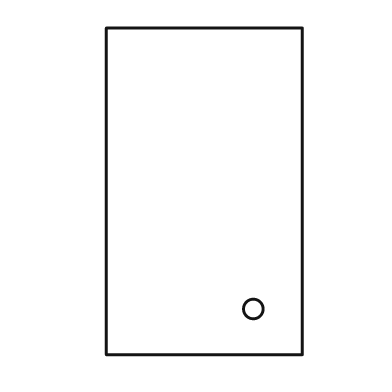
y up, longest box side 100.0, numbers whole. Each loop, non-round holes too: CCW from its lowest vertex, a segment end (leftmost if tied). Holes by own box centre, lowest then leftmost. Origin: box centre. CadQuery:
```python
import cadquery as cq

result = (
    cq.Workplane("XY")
    .moveTo(-30.0, -50.0)
    .lineTo(30.0, -50.0)
    .lineTo(30.0, 50.0)
    .lineTo(-30.0, 50.0)
    .close()
    .moveTo(15.0, -36.0)
    .circle(3.0)
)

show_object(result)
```